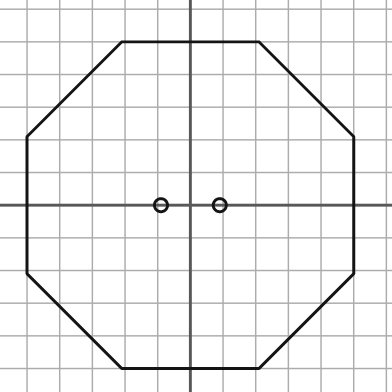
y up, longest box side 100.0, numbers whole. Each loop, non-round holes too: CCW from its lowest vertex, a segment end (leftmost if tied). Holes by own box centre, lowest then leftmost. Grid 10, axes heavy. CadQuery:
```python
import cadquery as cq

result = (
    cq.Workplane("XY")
    .moveTo(-21.0, -50.0)
    .lineTo(21.0, -50.0)
    .lineTo(50.0, -21.0)
    .lineTo(50.0, 21.0)
    .lineTo(21.0, 50.0)
    .lineTo(-21.0, 50.0)
    .lineTo(-50.0, 21.0)
    .lineTo(-50.0, -21.0)
    .close()
    .moveTo(-9.0, 0.0)
    .circle(2.0)
    .moveTo(9.0, 0.0)
    .circle(2.0)
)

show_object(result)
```